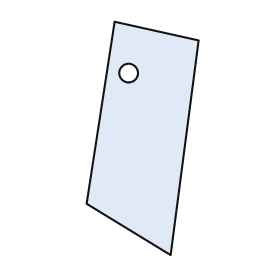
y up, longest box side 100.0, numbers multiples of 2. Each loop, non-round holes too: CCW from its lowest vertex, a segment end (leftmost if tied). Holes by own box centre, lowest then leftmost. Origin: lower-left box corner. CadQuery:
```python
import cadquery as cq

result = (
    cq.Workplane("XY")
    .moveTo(36.0, 0.0)
    .lineTo(48.0, 92.0)
    .lineTo(12.0, 100.0)
    .lineTo(0.0, 22.0)
    .close()
    .moveTo(18.0, 78.0)
    .circle(4.0)
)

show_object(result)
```